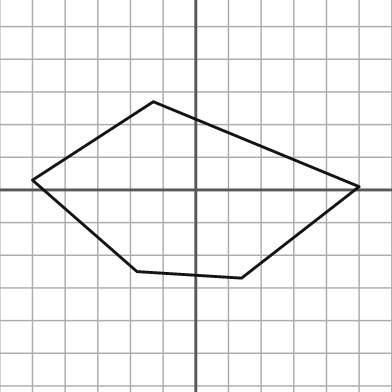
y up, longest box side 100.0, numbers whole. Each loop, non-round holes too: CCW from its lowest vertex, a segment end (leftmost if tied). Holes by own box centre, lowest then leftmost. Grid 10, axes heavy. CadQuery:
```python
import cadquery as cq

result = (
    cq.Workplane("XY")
    .moveTo(14.0, -27.0)
    .lineTo(50.0, 1.0)
    .lineTo(-13.0, 27.0)
    .lineTo(-50.0, 3.0)
    .lineTo(-18.0, -25.0)
    .close()
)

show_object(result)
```